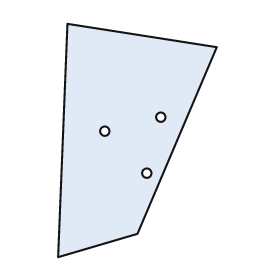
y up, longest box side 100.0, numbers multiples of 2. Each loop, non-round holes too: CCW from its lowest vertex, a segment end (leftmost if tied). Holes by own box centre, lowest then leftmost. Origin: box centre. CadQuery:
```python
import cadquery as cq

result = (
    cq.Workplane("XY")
    .moveTo(-34.0, -50.0)
    .lineTo(0.0, -40.0)
    .lineTo(34.0, 40.0)
    .lineTo(-30.0, 50.0)
    .close()
    .moveTo(4.0, -14.0)
    .circle(2.0)
    .moveTo(-14.0, 4.0)
    .circle(2.0)
    .moveTo(10.0, 10.0)
    .circle(2.0)
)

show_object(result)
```